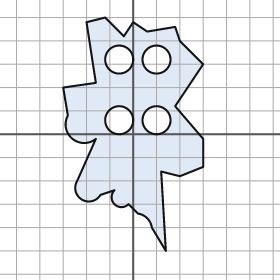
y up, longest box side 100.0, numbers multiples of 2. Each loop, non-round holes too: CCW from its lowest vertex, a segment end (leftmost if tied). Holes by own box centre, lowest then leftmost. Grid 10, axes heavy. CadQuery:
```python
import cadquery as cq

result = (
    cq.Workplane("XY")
    .moveTo(14.0, -50.0)
    .lineTo(12.0, -16.0)
    .lineTo(20.0, -18.0)
    .lineTo(30.0, -14.0)
    .lineTo(30.0, -2.0)
    .lineTo(18.0, 12.0)
    .lineTo(30.0, 30.0)
    .lineTo(20.0, 40.0)
    .lineTo(18.0, 46.0)
    .lineTo(6.0, 44.0)
    .lineTo(0.0, 48.0)
    .lineTo(-4.0, 42.0)
    .lineTo(-12.0, 50.0)
    .lineTo(-20.0, 48.0)
    .lineTo(-16.0, 22.0)
    .lineTo(-30.0, 20.0)
    .lineTo(-28.0, 8.0)
    .threePointArc((-26.0, -2.0), (-16.0, -2.0))
    .lineTo(-24.0, -20.0)
    .threePointArc((-22.0, -28.0), (-14.0, -26.0))
    .lineTo(-8.0, -24.0)
    .threePointArc((-8.0, -30.0), (-2.0, -30.0))
    .lineTo(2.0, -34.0)
    .threePointArc((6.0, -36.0), (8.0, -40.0))
    .close()
    .moveTo(-6.0, 6.0)
    .circle(6.0)
    .moveTo(10.0, 6.0)
    .circle(6.0)
    .moveTo(-6.0, 32.0)
    .circle(6.0)
    .moveTo(10.0, 32.0)
    .circle(6.0)
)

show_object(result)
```